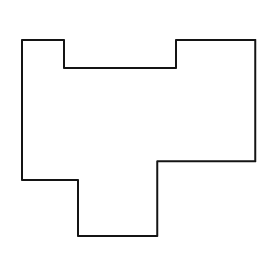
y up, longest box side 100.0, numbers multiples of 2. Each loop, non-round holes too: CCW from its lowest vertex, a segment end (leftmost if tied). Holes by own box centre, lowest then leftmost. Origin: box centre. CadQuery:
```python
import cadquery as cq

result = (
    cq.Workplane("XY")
    .moveTo(-26.0, -42.0)
    .lineTo(8.0, -42.0)
    .lineTo(8.0, -10.0)
    .lineTo(50.0, -10.0)
    .lineTo(50.0, 42.0)
    .lineTo(16.0, 42.0)
    .lineTo(16.0, 30.0)
    .lineTo(-32.0, 30.0)
    .lineTo(-32.0, 42.0)
    .lineTo(-50.0, 42.0)
    .lineTo(-50.0, -18.0)
    .lineTo(-26.0, -18.0)
    .close()
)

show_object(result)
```